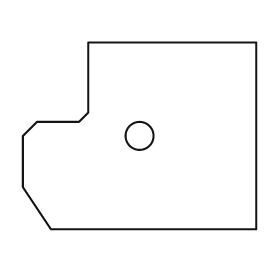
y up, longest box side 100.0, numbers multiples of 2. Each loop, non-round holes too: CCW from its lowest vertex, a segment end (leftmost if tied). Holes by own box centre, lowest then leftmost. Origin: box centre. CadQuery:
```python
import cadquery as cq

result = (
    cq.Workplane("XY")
    .moveTo(-38.0, -40.0)
    .lineTo(50.0, -40.0)
    .lineTo(50.0, 40.0)
    .lineTo(-22.0, 40.0)
    .lineTo(-22.0, 10.0)
    .lineTo(-26.0, 6.0)
    .lineTo(-44.0, 6.0)
    .lineTo(-50.0, 0.0)
    .lineTo(-50.0, -22.0)
    .close()
    .moveTo(0.0, 0.0)
    .circle(6.0)
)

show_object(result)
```